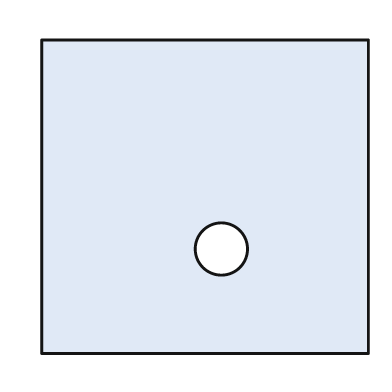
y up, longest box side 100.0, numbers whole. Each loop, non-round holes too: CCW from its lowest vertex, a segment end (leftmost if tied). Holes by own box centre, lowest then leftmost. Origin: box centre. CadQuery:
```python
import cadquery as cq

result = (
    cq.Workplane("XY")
    .moveTo(-50.0, -48.0)
    .lineTo(50.0, -48.0)
    .lineTo(50.0, 48.0)
    .lineTo(-50.0, 48.0)
    .close()
    .moveTo(5.0, -16.0)
    .circle(8.0)
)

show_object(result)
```